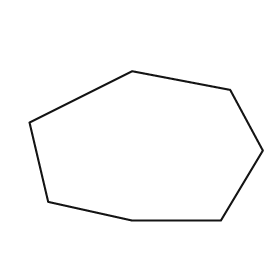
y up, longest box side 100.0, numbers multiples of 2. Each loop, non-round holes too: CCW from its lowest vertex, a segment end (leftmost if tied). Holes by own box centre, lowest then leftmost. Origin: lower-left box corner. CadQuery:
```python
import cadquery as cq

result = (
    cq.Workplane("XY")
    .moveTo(44.0, 0.0)
    .lineTo(82.0, 0.0)
    .lineTo(100.0, 30.0)
    .lineTo(86.0, 56.0)
    .lineTo(44.0, 64.0)
    .lineTo(0.0, 42.0)
    .lineTo(8.0, 8.0)
    .close()
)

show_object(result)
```